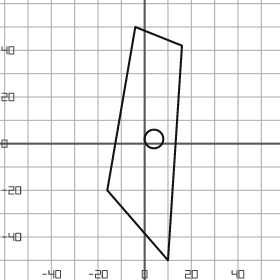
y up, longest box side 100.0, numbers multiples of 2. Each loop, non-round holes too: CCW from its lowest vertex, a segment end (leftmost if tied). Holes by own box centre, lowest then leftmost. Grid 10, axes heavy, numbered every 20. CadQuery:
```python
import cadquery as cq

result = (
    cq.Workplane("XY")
    .moveTo(10.0, -50.0)
    .lineTo(16.0, 42.0)
    .lineTo(-4.0, 50.0)
    .lineTo(-16.0, -20.0)
    .close()
    .moveTo(4.0, 2.0)
    .circle(4.0)
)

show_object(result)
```